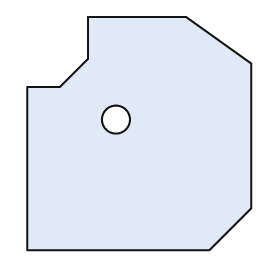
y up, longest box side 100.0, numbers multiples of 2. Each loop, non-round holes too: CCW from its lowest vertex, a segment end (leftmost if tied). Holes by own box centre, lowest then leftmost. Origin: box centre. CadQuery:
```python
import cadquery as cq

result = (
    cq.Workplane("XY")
    .moveTo(-48.0, -50.0)
    .lineTo(30.0, -50.0)
    .lineTo(48.0, -32.0)
    .lineTo(48.0, 30.0)
    .lineTo(20.0, 50.0)
    .lineTo(-22.0, 50.0)
    .lineTo(-22.0, 32.0)
    .lineTo(-34.0, 20.0)
    .lineTo(-48.0, 20.0)
    .close()
    .moveTo(-10.0, 6.0)
    .circle(6.0)
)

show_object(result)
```